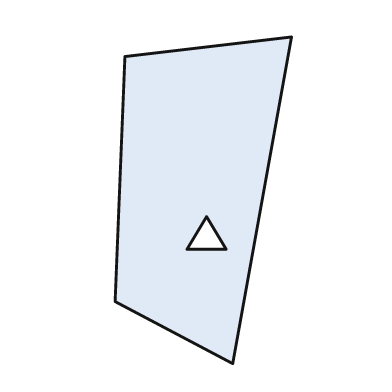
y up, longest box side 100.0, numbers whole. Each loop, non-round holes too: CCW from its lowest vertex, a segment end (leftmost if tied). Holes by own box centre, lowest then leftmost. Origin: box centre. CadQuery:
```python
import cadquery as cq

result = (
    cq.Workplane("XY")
    .moveTo(9.0, -50.0)
    .lineTo(27.0, 50.0)
    .lineTo(-24.0, 44.0)
    .lineTo(-27.0, -31.0)
    .close()
    .moveTo(-5.0, -15.0)
    .lineTo(7.0, -15.0)
    .lineTo(1.0, -5.0)
    .close()
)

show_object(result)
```